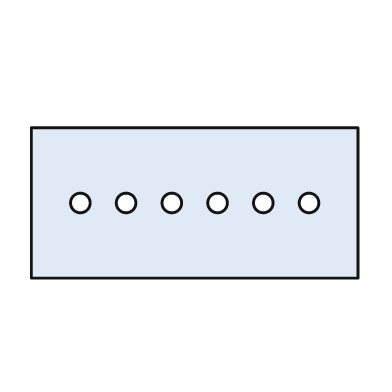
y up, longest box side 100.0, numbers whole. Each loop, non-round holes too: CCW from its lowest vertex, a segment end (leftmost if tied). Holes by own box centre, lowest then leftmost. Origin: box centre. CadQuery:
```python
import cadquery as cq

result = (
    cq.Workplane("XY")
    .moveTo(-50.0, -23.0)
    .lineTo(50.0, -23.0)
    .lineTo(50.0, 23.0)
    .lineTo(-50.0, 23.0)
    .close()
    .moveTo(-35.0, 0.0)
    .circle(3.0)
    .moveTo(-21.0, 0.0)
    .circle(3.0)
    .moveTo(-7.0, 0.0)
    .circle(3.0)
    .moveTo(7.0, 0.0)
    .circle(3.0)
    .moveTo(21.0, 0.0)
    .circle(3.0)
    .moveTo(35.0, 0.0)
    .circle(3.0)
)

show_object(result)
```